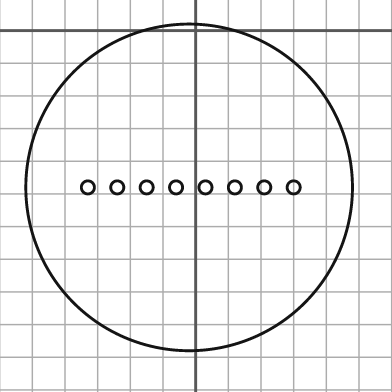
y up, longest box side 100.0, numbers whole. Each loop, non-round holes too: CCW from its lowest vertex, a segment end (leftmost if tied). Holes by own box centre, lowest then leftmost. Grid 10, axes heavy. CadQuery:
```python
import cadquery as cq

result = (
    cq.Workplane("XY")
    .moveTo(-2.0, -48.0)
    .circle(50.0)
    .moveTo(-33.0, -48.0)
    .circle(2.0)
    .moveTo(-24.0, -48.0)
    .circle(2.0)
    .moveTo(-15.0, -48.0)
    .circle(2.0)
    .moveTo(-6.0, -48.0)
    .circle(2.0)
    .moveTo(3.0, -48.0)
    .circle(2.0)
    .moveTo(12.0, -48.0)
    .circle(2.0)
    .moveTo(21.0, -48.0)
    .circle(2.0)
    .moveTo(30.0, -48.0)
    .circle(2.0)
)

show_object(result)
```